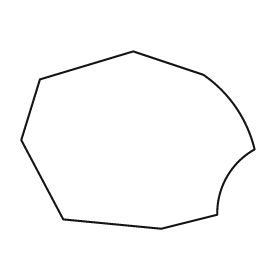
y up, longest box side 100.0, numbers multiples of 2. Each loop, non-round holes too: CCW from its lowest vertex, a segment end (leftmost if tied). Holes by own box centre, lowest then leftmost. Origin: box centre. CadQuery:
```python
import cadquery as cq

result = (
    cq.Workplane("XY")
    .moveTo(10.0, -38.0)
    .lineTo(34.0, -32.0)
    .threePointArc((38.0, -16.0), (50.0, -4.0))
    .threePointArc((42.0, 14.0), (28.0, 28.0))
    .lineTo(-2.0, 38.0)
    .lineTo(-42.0, 26.0)
    .lineTo(-50.0, 0.0)
    .lineTo(-32.0, -34.0)
    .close()
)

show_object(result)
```